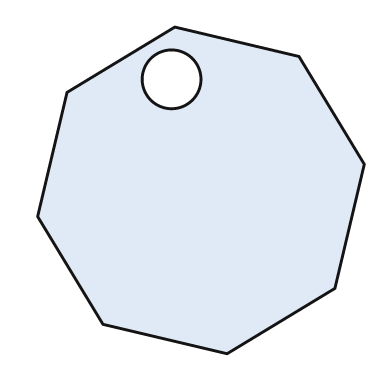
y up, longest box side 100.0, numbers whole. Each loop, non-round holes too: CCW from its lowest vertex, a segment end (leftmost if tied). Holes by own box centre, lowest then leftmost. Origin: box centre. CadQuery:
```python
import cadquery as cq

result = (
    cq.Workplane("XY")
    .moveTo(8.0, -50.0)
    .lineTo(41.0, -30.0)
    .lineTo(50.0, 8.0)
    .lineTo(30.0, 41.0)
    .lineTo(-8.0, 50.0)
    .lineTo(-41.0, 30.0)
    .lineTo(-50.0, -8.0)
    .lineTo(-30.0, -41.0)
    .close()
    .moveTo(-9.0, 34.0)
    .circle(9.0)
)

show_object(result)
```